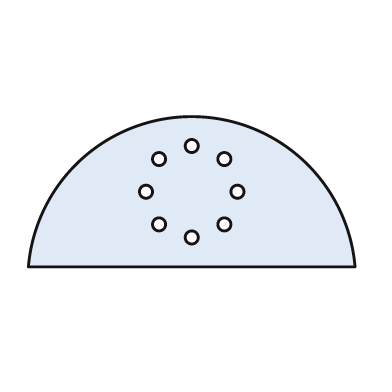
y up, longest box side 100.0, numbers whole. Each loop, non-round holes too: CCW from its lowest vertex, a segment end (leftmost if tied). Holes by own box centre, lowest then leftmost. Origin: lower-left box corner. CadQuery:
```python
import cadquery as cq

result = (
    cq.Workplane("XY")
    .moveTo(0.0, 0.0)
    .lineTo(100.0, 0.0)
    .threePointArc((50.0, 46.0), (0.0, 0.0))
    .close()
    .moveTo(50.0, 9.0)
    .circle(2.0)
    .moveTo(40.0, 13.0)
    .circle(2.0)
    .moveTo(60.0, 13.0)
    .circle(2.0)
    .moveTo(36.0, 23.0)
    .circle(2.0)
    .moveTo(64.0, 23.0)
    .circle(2.0)
    .moveTo(40.0, 33.0)
    .circle(2.0)
    .moveTo(60.0, 33.0)
    .circle(2.0)
    .moveTo(50.0, 37.0)
    .circle(2.0)
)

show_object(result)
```